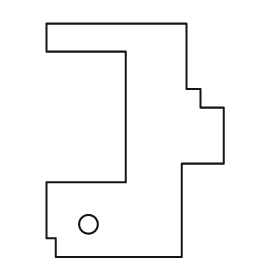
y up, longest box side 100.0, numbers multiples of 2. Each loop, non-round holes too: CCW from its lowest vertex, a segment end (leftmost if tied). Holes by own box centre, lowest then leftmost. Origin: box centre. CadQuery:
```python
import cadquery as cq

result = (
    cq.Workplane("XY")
    .moveTo(-34.0, -50.0)
    .lineTo(20.0, -50.0)
    .lineTo(20.0, -10.0)
    .lineTo(38.0, -10.0)
    .lineTo(38.0, 14.0)
    .lineTo(28.0, 14.0)
    .lineTo(28.0, 22.0)
    .lineTo(22.0, 22.0)
    .lineTo(22.0, 50.0)
    .lineTo(-38.0, 50.0)
    .lineTo(-38.0, 38.0)
    .lineTo(-4.0, 38.0)
    .lineTo(-4.0, -18.0)
    .lineTo(-38.0, -18.0)
    .lineTo(-38.0, -42.0)
    .lineTo(-34.0, -42.0)
    .close()
    .moveTo(-20.0, -36.0)
    .circle(4.0)
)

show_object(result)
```